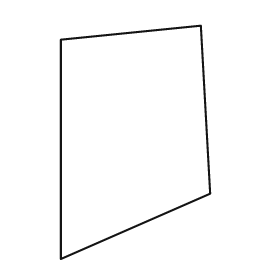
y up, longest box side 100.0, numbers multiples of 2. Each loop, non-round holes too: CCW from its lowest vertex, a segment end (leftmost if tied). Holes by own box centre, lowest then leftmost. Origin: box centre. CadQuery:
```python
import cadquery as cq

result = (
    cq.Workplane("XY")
    .moveTo(-32.0, -50.0)
    .lineTo(32.0, -22.0)
    .lineTo(28.0, 50.0)
    .lineTo(-32.0, 44.0)
    .close()
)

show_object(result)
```